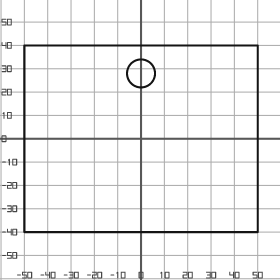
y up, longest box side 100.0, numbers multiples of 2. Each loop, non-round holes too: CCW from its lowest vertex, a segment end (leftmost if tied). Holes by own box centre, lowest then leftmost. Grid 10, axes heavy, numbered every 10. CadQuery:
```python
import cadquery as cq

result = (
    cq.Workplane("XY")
    .moveTo(-50.0, -40.0)
    .lineTo(50.0, -40.0)
    .lineTo(50.0, 40.0)
    .lineTo(-50.0, 40.0)
    .close()
    .moveTo(0.0, 28.0)
    .circle(6.0)
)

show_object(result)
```